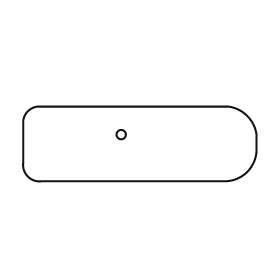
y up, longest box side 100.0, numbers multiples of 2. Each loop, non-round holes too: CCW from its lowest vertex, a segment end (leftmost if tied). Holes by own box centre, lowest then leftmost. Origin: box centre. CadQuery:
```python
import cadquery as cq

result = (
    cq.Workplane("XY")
    .moveTo(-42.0, -16.0)
    .lineTo(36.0, -16.0)
    .threePointArc((46.0, -12.0), (50.0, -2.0))
    .lineTo(50.0, 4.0)
    .threePointArc((46.0, 12.0), (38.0, 16.0))
    .lineTo(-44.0, 16.0)
    .threePointArc((-48.0, 14.0), (-50.0, 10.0))
    .lineTo(-50.0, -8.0)
    .threePointArc((-48.0, -14.0), (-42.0, -16.0))
    .close()
    .moveTo(-8.0, 4.0)
    .circle(2.0)
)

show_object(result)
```